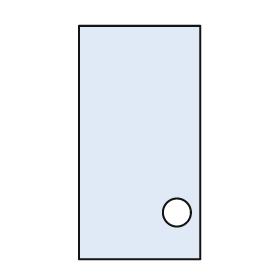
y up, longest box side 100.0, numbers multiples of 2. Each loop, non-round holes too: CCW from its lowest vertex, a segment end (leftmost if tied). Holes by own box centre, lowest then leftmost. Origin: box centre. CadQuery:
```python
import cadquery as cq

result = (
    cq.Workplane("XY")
    .moveTo(-26.0, -50.0)
    .lineTo(26.0, -50.0)
    .lineTo(26.0, 50.0)
    .lineTo(-26.0, 50.0)
    .close()
    .moveTo(16.0, -30.0)
    .circle(6.0)
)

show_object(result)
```